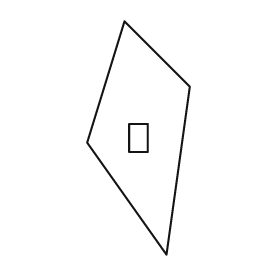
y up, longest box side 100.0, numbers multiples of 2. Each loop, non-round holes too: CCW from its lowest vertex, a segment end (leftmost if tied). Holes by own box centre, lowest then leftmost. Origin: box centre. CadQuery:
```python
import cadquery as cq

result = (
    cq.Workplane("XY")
    .moveTo(12.0, -50.0)
    .lineTo(22.0, 22.0)
    .lineTo(-6.0, 50.0)
    .lineTo(-22.0, -2.0)
    .close()
    .moveTo(-4.0, -6.0)
    .lineTo(4.0, -6.0)
    .lineTo(4.0, 6.0)
    .lineTo(-4.0, 6.0)
    .close()
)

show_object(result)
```